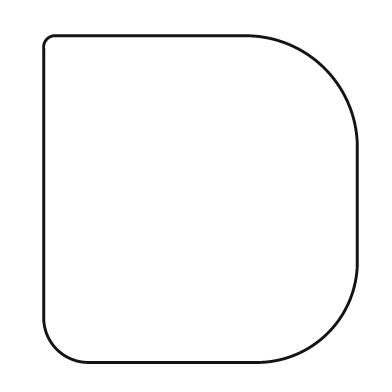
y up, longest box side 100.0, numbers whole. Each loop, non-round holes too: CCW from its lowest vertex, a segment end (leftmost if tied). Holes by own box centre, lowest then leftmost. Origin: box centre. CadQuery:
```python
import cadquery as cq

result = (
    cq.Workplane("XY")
    .moveTo(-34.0, -50.0)
    .lineTo(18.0, -50.0)
    .threePointArc((39.0, -41.0), (48.0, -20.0))
    .lineTo(48.0, 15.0)
    .threePointArc((38.0, 40.0), (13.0, 50.0))
    .lineTo(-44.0, 50.0)
    .threePointArc((-47.0, 49.0), (-48.0, 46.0))
    .lineTo(-48.0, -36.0)
    .threePointArc((-44.0, -46.0), (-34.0, -50.0))
    .close()
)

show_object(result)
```